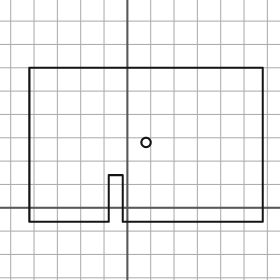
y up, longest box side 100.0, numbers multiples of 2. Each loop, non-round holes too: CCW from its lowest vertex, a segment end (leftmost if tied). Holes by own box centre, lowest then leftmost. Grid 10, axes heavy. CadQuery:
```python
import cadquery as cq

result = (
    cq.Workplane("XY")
    .moveTo(-42.0, -6.0)
    .lineTo(-8.0, -6.0)
    .lineTo(-8.0, 14.0)
    .lineTo(-2.0, 14.0)
    .lineTo(-2.0, -6.0)
    .lineTo(58.0, -6.0)
    .lineTo(58.0, 60.0)
    .lineTo(-42.0, 60.0)
    .close()
    .moveTo(8.0, 28.0)
    .circle(2.0)
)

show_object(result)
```